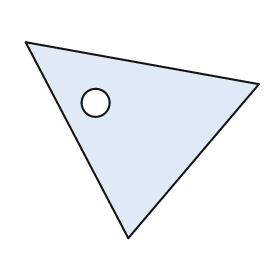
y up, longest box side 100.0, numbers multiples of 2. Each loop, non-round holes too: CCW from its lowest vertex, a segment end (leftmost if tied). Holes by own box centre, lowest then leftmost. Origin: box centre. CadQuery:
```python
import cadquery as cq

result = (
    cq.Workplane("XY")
    .moveTo(-6.0, -42.0)
    .lineTo(50.0, 24.0)
    .lineTo(-50.0, 42.0)
    .close()
    .moveTo(-20.0, 16.0)
    .circle(6.0)
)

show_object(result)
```